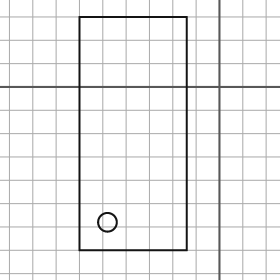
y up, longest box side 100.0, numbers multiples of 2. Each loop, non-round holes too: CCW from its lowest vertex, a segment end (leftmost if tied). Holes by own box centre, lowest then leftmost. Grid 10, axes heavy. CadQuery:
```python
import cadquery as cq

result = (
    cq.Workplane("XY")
    .moveTo(-60.0, -70.0)
    .lineTo(-14.0, -70.0)
    .lineTo(-14.0, 30.0)
    .lineTo(-60.0, 30.0)
    .close()
    .moveTo(-48.0, -58.0)
    .circle(4.0)
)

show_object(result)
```